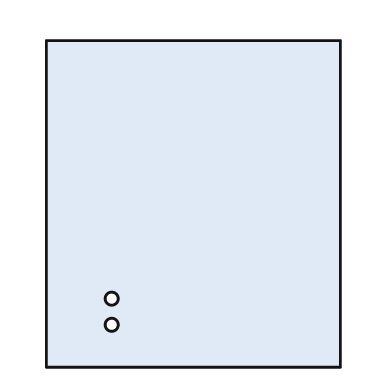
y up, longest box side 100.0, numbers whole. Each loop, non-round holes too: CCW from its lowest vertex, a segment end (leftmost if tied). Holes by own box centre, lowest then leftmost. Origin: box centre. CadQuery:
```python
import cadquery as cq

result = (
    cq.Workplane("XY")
    .moveTo(-45.0, -50.0)
    .lineTo(45.0, -50.0)
    .lineTo(45.0, 50.0)
    .lineTo(-45.0, 50.0)
    .close()
    .moveTo(-25.0, -37.0)
    .circle(2.0)
    .moveTo(-25.0, -29.0)
    .circle(2.0)
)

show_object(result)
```